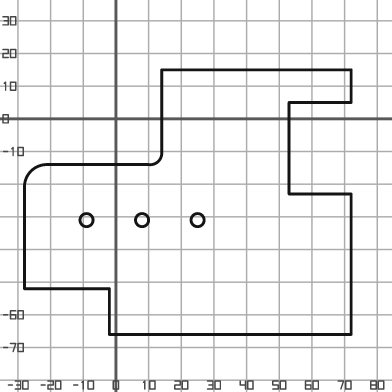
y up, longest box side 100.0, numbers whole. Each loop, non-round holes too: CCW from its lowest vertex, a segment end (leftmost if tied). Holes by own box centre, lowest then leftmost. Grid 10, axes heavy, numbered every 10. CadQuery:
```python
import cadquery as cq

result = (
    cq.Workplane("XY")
    .moveTo(-2.0, -66.0)
    .lineTo(72.0, -66.0)
    .lineTo(72.0, -23.0)
    .lineTo(53.0, -23.0)
    .lineTo(53.0, 5.0)
    .lineTo(72.0, 5.0)
    .lineTo(72.0, 15.0)
    .lineTo(14.0, 15.0)
    .lineTo(14.0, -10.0)
    .threePointArc((13.0, -13.0), (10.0, -14.0))
    .lineTo(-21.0, -14.0)
    .threePointArc((-26.0, -16.0), (-28.0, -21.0))
    .lineTo(-28.0, -52.0)
    .lineTo(-2.0, -52.0)
    .close()
    .moveTo(-9.0, -31.0)
    .circle(2.0)
    .moveTo(8.0, -31.0)
    .circle(2.0)
    .moveTo(25.0, -31.0)
    .circle(2.0)
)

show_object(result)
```